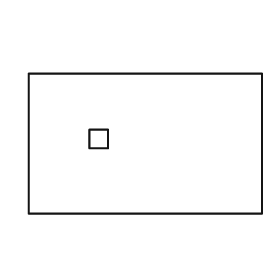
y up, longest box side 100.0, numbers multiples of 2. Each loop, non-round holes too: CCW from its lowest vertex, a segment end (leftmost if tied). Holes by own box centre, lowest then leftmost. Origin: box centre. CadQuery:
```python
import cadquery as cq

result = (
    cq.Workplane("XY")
    .moveTo(-50.0, -30.0)
    .lineTo(50.0, -30.0)
    .lineTo(50.0, 30.0)
    .lineTo(-50.0, 30.0)
    .close()
    .moveTo(-24.0, -2.0)
    .lineTo(-16.0, -2.0)
    .lineTo(-16.0, 6.0)
    .lineTo(-24.0, 6.0)
    .close()
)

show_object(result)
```